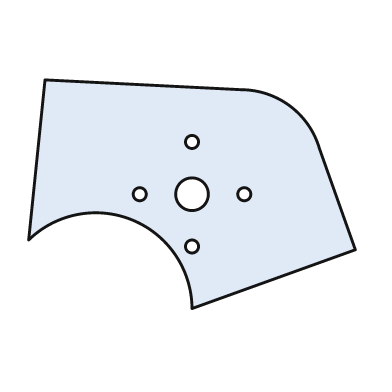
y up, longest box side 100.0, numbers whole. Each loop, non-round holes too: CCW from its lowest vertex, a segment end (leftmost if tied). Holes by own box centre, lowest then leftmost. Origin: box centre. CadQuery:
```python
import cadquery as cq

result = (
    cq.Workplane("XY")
    .moveTo(0.0, -35.0)
    .lineTo(50.0, -17.0)
    .lineTo(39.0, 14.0)
    .threePointArc((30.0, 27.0), (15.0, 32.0))
    .lineTo(-45.0, 35.0)
    .lineTo(-50.0, -14.0)
    .threePointArc((-18.0, -8.0), (0.0, -35.0))
    .close()
    .moveTo(0.0, -16.0)
    .circle(2.0)
    .moveTo(-16.0, 0.0)
    .circle(2.0)
    .moveTo(0.0, 0.0)
    .circle(5.0)
    .moveTo(16.0, 0.0)
    .circle(2.0)
    .moveTo(0.0, 16.0)
    .circle(2.0)
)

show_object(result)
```